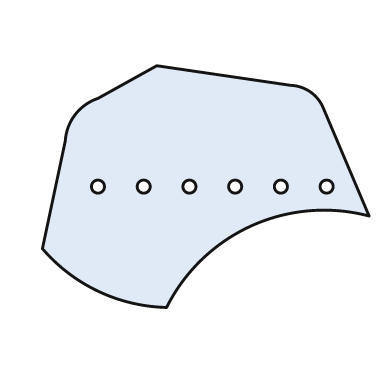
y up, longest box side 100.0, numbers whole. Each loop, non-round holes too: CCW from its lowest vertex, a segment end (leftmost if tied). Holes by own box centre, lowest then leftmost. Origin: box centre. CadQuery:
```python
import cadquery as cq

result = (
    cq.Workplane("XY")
    .moveTo(-12.0, -37.0)
    .threePointArc((14.0, -12.0), (50.0, -9.0))
    .lineTo(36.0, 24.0)
    .threePointArc((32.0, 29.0), (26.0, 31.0))
    .lineTo(-15.0, 37.0)
    .lineTo(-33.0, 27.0)
    .threePointArc((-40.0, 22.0), (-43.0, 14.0))
    .lineTo(-50.0, -19.0)
    .threePointArc((-33.0, -32.0), (-12.0, -37.0))
    .close()
    .moveTo(-33.0, 0.0)
    .circle(2.0)
    .moveTo(-19.0, 0.0)
    .circle(2.0)
    .moveTo(-5.0, 0.0)
    .circle(2.0)
    .moveTo(9.0, 0.0)
    .circle(2.0)
    .moveTo(23.0, 0.0)
    .circle(2.0)
    .moveTo(37.0, 0.0)
    .circle(2.0)
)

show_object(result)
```